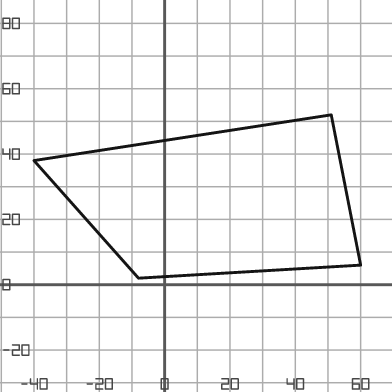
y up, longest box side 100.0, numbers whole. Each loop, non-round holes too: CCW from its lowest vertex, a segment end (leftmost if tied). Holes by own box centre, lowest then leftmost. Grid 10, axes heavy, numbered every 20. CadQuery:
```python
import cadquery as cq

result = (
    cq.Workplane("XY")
    .moveTo(-8.0, 2.0)
    .lineTo(60.0, 6.0)
    .lineTo(51.0, 52.0)
    .lineTo(-40.0, 38.0)
    .close()
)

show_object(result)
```